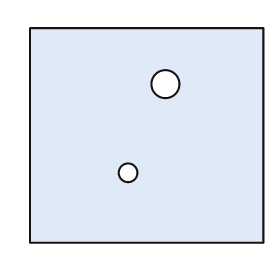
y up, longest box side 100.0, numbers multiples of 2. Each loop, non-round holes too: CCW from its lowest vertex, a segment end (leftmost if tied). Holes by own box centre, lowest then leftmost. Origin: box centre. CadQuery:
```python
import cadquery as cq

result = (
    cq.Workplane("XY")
    .moveTo(-50.0, -46.0)
    .lineTo(50.0, -46.0)
    .lineTo(50.0, 46.0)
    .lineTo(-50.0, 46.0)
    .close()
    .moveTo(-8.0, -16.0)
    .circle(4.0)
    .moveTo(8.0, 22.0)
    .circle(6.0)
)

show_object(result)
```